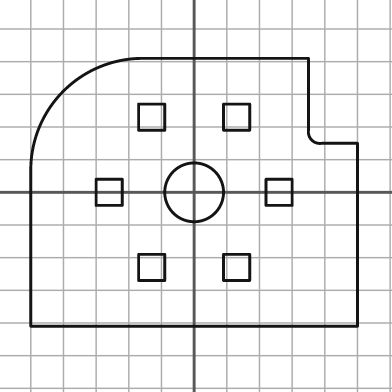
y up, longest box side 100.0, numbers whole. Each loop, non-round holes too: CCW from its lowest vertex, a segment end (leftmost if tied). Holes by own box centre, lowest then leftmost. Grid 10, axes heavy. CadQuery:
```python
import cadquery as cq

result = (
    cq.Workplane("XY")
    .moveTo(-50.0, -41.0)
    .lineTo(50.0, -41.0)
    .lineTo(50.0, 15.0)
    .lineTo(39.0, 15.0)
    .threePointArc((36.0, 16.0), (35.0, 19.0))
    .lineTo(35.0, 41.0)
    .lineTo(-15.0, 41.0)
    .threePointArc((-40.0, 31.0), (-50.0, 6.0))
    .close()
    .moveTo(-17.0, -27.0)
    .lineTo(-9.0, -27.0)
    .lineTo(-9.0, -19.0)
    .lineTo(-17.0, -19.0)
    .close()
    .moveTo(9.0, -27.0)
    .lineTo(17.0, -27.0)
    .lineTo(17.0, -19.0)
    .lineTo(9.0, -19.0)
    .close()
    .moveTo(-30.0, -4.0)
    .lineTo(-22.0, -4.0)
    .lineTo(-22.0, 4.0)
    .lineTo(-30.0, 4.0)
    .close()
    .moveTo(0.0, 0.0)
    .circle(9.0)
    .moveTo(22.0, -4.0)
    .lineTo(30.0, -4.0)
    .lineTo(30.0, 4.0)
    .lineTo(22.0, 4.0)
    .close()
    .moveTo(-17.0, 19.0)
    .lineTo(-9.0, 19.0)
    .lineTo(-9.0, 27.0)
    .lineTo(-17.0, 27.0)
    .close()
    .moveTo(9.0, 19.0)
    .lineTo(17.0, 19.0)
    .lineTo(17.0, 27.0)
    .lineTo(9.0, 27.0)
    .close()
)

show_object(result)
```